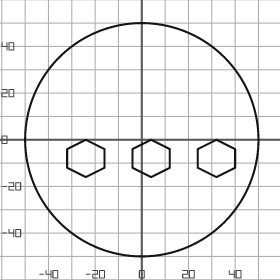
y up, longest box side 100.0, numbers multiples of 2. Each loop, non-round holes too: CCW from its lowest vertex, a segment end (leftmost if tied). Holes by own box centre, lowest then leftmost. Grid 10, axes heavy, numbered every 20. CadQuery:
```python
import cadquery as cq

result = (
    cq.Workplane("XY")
    .moveTo(0.0, 0.0)
    .circle(50.0)
    .moveTo(-24.0, -16.0)
    .lineTo(-16.0, -12.0)
    .lineTo(-16.0, -4.0)
    .lineTo(-24.0, 0.0)
    .lineTo(-32.0, -4.0)
    .lineTo(-32.0, -12.0)
    .close()
    .moveTo(4.0, -16.0)
    .lineTo(12.0, -12.0)
    .lineTo(12.0, -4.0)
    .lineTo(4.0, 0.0)
    .lineTo(-4.0, -4.0)
    .lineTo(-4.0, -12.0)
    .close()
    .moveTo(32.0, -16.0)
    .lineTo(40.0, -12.0)
    .lineTo(40.0, -4.0)
    .lineTo(32.0, 0.0)
    .lineTo(24.0, -4.0)
    .lineTo(24.0, -12.0)
    .close()
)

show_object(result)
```